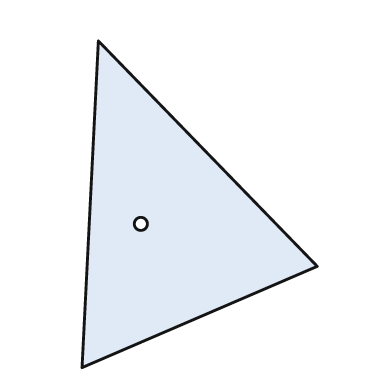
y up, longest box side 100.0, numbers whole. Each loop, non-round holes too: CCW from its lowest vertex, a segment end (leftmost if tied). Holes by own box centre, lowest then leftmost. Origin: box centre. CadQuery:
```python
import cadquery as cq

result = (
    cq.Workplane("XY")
    .moveTo(-36.0, -50.0)
    .lineTo(36.0, -19.0)
    .lineTo(-31.0, 50.0)
    .close()
    .moveTo(-18.0, -6.0)
    .circle(2.0)
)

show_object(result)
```